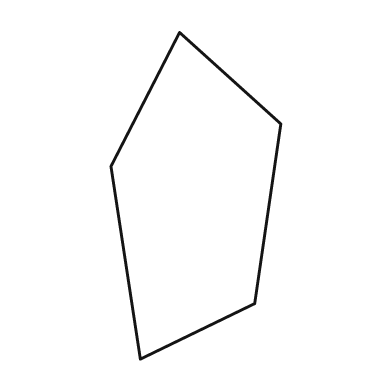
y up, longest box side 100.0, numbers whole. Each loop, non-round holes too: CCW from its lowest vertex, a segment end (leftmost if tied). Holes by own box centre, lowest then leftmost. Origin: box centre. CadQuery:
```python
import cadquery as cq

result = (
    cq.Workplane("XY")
    .moveTo(-17.0, -50.0)
    .lineTo(18.0, -33.0)
    .lineTo(26.0, 22.0)
    .lineTo(-5.0, 50.0)
    .lineTo(-26.0, 9.0)
    .close()
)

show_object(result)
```